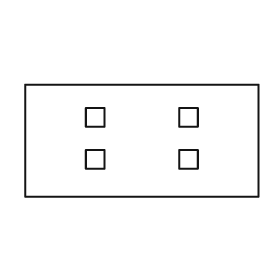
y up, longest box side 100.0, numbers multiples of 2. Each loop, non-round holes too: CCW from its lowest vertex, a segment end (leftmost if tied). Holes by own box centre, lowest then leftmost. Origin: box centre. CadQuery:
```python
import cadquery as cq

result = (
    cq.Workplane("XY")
    .moveTo(-50.0, -24.0)
    .lineTo(50.0, -24.0)
    .lineTo(50.0, 24.0)
    .lineTo(-50.0, 24.0)
    .close()
    .moveTo(-24.0, -12.0)
    .lineTo(-16.0, -12.0)
    .lineTo(-16.0, -4.0)
    .lineTo(-24.0, -4.0)
    .close()
    .moveTo(16.0, -12.0)
    .lineTo(24.0, -12.0)
    .lineTo(24.0, -4.0)
    .lineTo(16.0, -4.0)
    .close()
    .moveTo(-24.0, 6.0)
    .lineTo(-16.0, 6.0)
    .lineTo(-16.0, 14.0)
    .lineTo(-24.0, 14.0)
    .close()
    .moveTo(16.0, 6.0)
    .lineTo(24.0, 6.0)
    .lineTo(24.0, 14.0)
    .lineTo(16.0, 14.0)
    .close()
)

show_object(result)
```